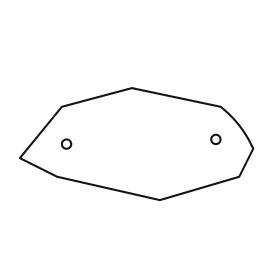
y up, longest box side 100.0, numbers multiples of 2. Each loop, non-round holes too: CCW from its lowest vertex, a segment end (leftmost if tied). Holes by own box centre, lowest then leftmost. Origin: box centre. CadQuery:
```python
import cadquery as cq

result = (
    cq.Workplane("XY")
    .moveTo(10.0, -24.0)
    .lineTo(44.0, -14.0)
    .lineTo(50.0, -2.0)
    .threePointArc((44.0, 8.0), (36.0, 16.0))
    .lineTo(-2.0, 24.0)
    .lineTo(-32.0, 16.0)
    .lineTo(-50.0, -6.0)
    .lineTo(-34.0, -14.0)
    .close()
    .moveTo(-30.0, 0.0)
    .circle(2.0)
    .moveTo(34.0, 2.0)
    .circle(2.0)
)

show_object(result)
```